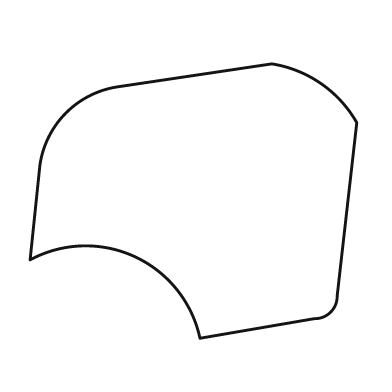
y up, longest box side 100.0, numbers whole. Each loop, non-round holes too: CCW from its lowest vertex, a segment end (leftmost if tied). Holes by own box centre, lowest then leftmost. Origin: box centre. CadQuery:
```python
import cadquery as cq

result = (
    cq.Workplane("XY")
    .moveTo(2.0, -42.0)
    .lineTo(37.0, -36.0)
    .threePointArc((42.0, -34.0), (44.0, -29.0))
    .lineTo(50.0, 24.0)
    .threePointArc((39.0, 36.0), (24.0, 42.0))
    .lineTo(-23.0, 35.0)
    .threePointArc((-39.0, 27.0), (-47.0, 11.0))
    .lineTo(-50.0, -18.0)
    .threePointArc((-18.0, -17.0), (2.0, -42.0))
    .close()
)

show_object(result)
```